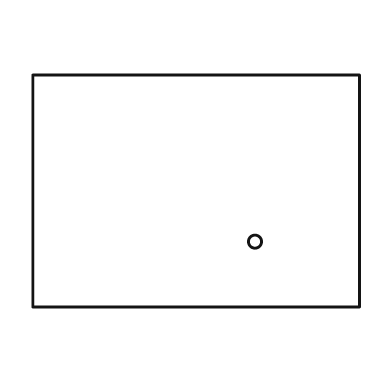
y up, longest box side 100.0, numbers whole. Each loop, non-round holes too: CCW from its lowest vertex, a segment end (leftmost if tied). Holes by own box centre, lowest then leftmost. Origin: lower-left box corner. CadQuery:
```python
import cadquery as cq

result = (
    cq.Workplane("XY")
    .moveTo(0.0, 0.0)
    .lineTo(100.0, 0.0)
    .lineTo(100.0, 71.0)
    .lineTo(0.0, 71.0)
    .close()
    .moveTo(68.0, 20.0)
    .circle(2.0)
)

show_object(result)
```